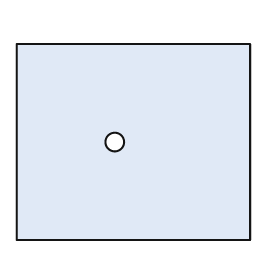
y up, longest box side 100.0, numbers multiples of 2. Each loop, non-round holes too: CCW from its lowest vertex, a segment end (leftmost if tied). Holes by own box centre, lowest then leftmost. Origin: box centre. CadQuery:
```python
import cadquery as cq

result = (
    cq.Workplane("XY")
    .moveTo(-50.0, -42.0)
    .lineTo(50.0, -42.0)
    .lineTo(50.0, 42.0)
    .lineTo(-50.0, 42.0)
    .close()
    .moveTo(-8.0, 0.0)
    .circle(4.0)
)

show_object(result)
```